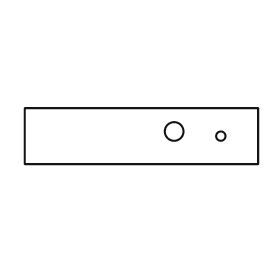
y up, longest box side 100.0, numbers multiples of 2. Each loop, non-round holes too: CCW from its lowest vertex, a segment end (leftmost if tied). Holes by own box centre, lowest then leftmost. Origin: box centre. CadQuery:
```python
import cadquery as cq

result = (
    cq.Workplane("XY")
    .moveTo(-50.0, -12.0)
    .lineTo(50.0, -12.0)
    .lineTo(50.0, 12.0)
    .lineTo(-50.0, 12.0)
    .close()
    .moveTo(34.0, 0.0)
    .circle(2.0)
    .moveTo(14.0, 2.0)
    .circle(4.0)
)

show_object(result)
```